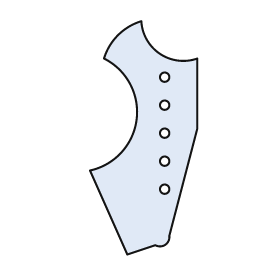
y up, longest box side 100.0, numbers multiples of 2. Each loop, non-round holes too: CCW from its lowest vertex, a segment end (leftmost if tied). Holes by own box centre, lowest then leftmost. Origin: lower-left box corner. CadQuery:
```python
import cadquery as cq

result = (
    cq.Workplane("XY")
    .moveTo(16.0, 0.0)
    .lineTo(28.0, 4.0)
    .threePointArc((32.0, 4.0), (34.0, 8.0))
    .lineTo(46.0, 54.0)
    .lineTo(46.0, 84.0)
    .threePointArc((30.0, 86.0), (22.0, 100.0))
    .threePointArc((12.0, 94.0), (6.0, 84.0))
    .threePointArc((20.0, 58.0), (0.0, 36.0))
    .close()
    .moveTo(32.0, 28.0)
    .circle(2.0)
    .moveTo(32.0, 40.0)
    .circle(2.0)
    .moveTo(32.0, 52.0)
    .circle(2.0)
    .moveTo(32.0, 64.0)
    .circle(2.0)
    .moveTo(32.0, 76.0)
    .circle(2.0)
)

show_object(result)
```